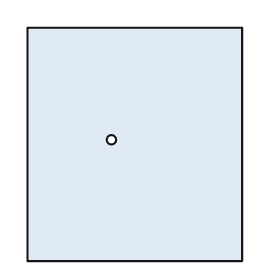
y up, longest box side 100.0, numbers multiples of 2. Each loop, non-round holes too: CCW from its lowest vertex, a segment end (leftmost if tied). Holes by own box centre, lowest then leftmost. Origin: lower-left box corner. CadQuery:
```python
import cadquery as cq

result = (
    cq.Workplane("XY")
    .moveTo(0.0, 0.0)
    .lineTo(92.0, 0.0)
    .lineTo(92.0, 100.0)
    .lineTo(0.0, 100.0)
    .close()
    .moveTo(36.0, 52.0)
    .circle(2.0)
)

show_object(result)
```